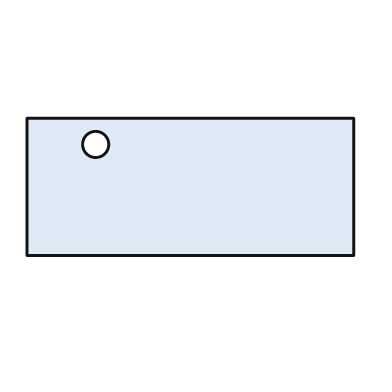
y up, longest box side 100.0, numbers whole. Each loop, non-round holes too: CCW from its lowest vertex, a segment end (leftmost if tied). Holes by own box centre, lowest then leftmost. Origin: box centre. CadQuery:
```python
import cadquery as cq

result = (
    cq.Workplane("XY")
    .moveTo(-50.0, -21.0)
    .lineTo(50.0, -21.0)
    .lineTo(50.0, 21.0)
    .lineTo(-50.0, 21.0)
    .close()
    .moveTo(-29.0, 13.0)
    .circle(4.0)
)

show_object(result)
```